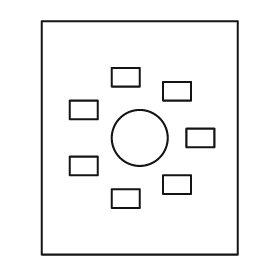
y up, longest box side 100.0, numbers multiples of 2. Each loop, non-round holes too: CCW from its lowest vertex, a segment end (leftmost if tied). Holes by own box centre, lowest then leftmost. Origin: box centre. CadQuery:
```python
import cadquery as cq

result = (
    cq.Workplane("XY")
    .moveTo(-42.0, -50.0)
    .lineTo(42.0, -50.0)
    .lineTo(42.0, 50.0)
    .lineTo(-42.0, 50.0)
    .close()
    .moveTo(-12.0, -30.0)
    .lineTo(0.0, -30.0)
    .lineTo(0.0, -22.0)
    .lineTo(-12.0, -22.0)
    .close()
    .moveTo(10.0, -24.0)
    .lineTo(22.0, -24.0)
    .lineTo(22.0, -16.0)
    .lineTo(10.0, -16.0)
    .close()
    .moveTo(-30.0, -16.0)
    .lineTo(-18.0, -16.0)
    .lineTo(-18.0, -8.0)
    .lineTo(-30.0, -8.0)
    .close()
    .moveTo(0.0, 0.0)
    .circle(12.0)
    .moveTo(20.0, -4.0)
    .lineTo(32.0, -4.0)
    .lineTo(32.0, 4.0)
    .lineTo(20.0, 4.0)
    .close()
    .moveTo(-30.0, 8.0)
    .lineTo(-18.0, 8.0)
    .lineTo(-18.0, 16.0)
    .lineTo(-30.0, 16.0)
    .close()
    .moveTo(10.0, 16.0)
    .lineTo(22.0, 16.0)
    .lineTo(22.0, 24.0)
    .lineTo(10.0, 24.0)
    .close()
    .moveTo(-12.0, 22.0)
    .lineTo(0.0, 22.0)
    .lineTo(0.0, 30.0)
    .lineTo(-12.0, 30.0)
    .close()
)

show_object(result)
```